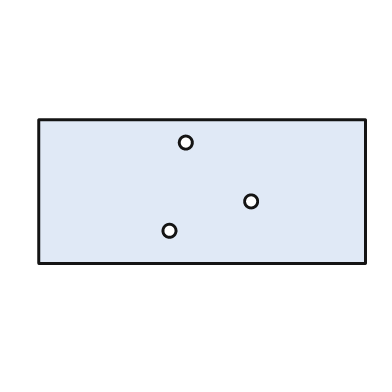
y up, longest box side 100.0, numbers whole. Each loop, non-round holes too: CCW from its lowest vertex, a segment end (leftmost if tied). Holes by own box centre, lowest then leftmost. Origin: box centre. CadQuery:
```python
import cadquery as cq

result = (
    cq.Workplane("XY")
    .moveTo(-50.0, -22.0)
    .lineTo(50.0, -22.0)
    .lineTo(50.0, 22.0)
    .lineTo(-50.0, 22.0)
    .close()
    .moveTo(-10.0, -12.0)
    .circle(2.0)
    .moveTo(15.0, -3.0)
    .circle(2.0)
    .moveTo(-5.0, 15.0)
    .circle(2.0)
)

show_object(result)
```